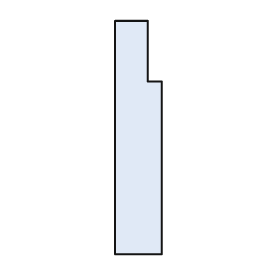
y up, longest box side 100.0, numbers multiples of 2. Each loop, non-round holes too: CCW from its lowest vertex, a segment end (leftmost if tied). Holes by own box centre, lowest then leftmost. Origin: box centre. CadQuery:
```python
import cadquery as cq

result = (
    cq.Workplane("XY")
    .moveTo(-10.0, -50.0)
    .lineTo(10.0, -50.0)
    .lineTo(10.0, 24.0)
    .lineTo(4.0, 24.0)
    .lineTo(4.0, 50.0)
    .lineTo(-10.0, 50.0)
    .close()
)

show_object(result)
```